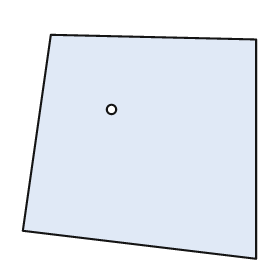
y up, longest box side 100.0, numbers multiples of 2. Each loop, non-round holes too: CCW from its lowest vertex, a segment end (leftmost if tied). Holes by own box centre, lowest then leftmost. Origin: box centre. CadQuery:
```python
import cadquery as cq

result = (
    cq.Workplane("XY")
    .moveTo(50.0, -48.0)
    .lineTo(50.0, 46.0)
    .lineTo(-38.0, 48.0)
    .lineTo(-50.0, -36.0)
    .close()
    .moveTo(-12.0, 16.0)
    .circle(2.0)
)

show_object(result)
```